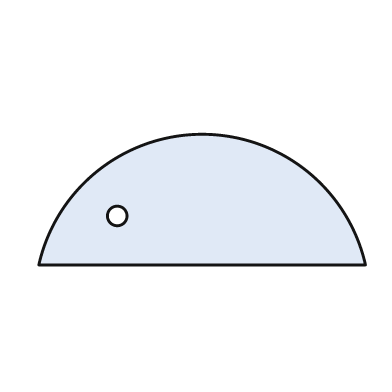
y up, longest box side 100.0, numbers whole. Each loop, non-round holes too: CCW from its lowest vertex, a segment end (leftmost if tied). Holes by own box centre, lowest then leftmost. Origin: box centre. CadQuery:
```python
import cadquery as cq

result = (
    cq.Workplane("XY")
    .moveTo(-50.0, -20.0)
    .lineTo(50.0, -20.0)
    .threePointArc((0.0, 20.0), (-50.0, -20.0))
    .close()
    .moveTo(-26.0, -5.0)
    .circle(3.0)
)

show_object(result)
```